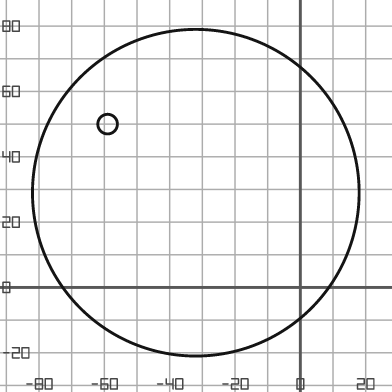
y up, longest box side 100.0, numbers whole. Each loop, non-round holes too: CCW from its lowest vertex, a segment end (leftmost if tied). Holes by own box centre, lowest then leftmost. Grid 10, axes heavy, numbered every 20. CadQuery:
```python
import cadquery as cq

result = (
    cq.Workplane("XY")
    .moveTo(-32.0, 29.0)
    .circle(50.0)
    .moveTo(-59.0, 50.0)
    .circle(3.0)
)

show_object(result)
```